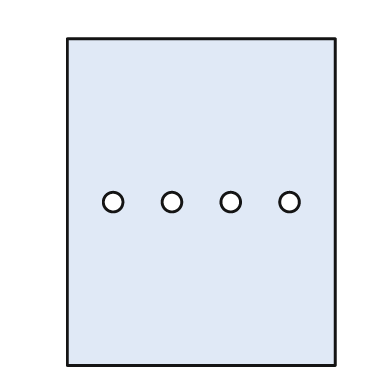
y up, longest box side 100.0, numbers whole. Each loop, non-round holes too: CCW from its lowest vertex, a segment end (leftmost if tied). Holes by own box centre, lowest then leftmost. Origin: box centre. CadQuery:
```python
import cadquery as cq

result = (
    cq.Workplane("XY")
    .moveTo(-41.0, -50.0)
    .lineTo(41.0, -50.0)
    .lineTo(41.0, 50.0)
    .lineTo(-41.0, 50.0)
    .close()
    .moveTo(-27.0, 0.0)
    .circle(3.0)
    .moveTo(-9.0, 0.0)
    .circle(3.0)
    .moveTo(9.0, 0.0)
    .circle(3.0)
    .moveTo(27.0, 0.0)
    .circle(3.0)
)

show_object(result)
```